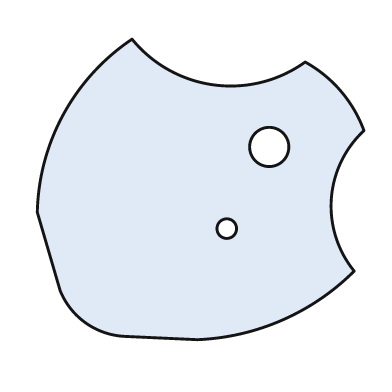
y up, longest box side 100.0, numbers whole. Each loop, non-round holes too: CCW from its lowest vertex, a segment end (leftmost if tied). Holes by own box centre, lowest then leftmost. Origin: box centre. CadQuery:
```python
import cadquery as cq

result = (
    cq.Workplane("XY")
    .moveTo(-1.0, -46.0)
    .threePointArc((25.0, -40.0), (47.0, -25.0))
    .threePointArc((40.0, -3.0), (50.0, 18.0))
    .threePointArc((43.0, 30.0), (32.0, 39.0))
    .threePointArc((4.0, 32.0), (-21.0, 46.0))
    .threePointArc((-42.0, 23.0), (-50.0, -7.0))
    .lineTo(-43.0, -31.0)
    .threePointArc((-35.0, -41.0), (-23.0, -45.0))
    .close()
    .moveTo(8.0, -12.0)
    .circle(3.0)
    .moveTo(21.0, 13.0)
    .circle(6.0)
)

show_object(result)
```